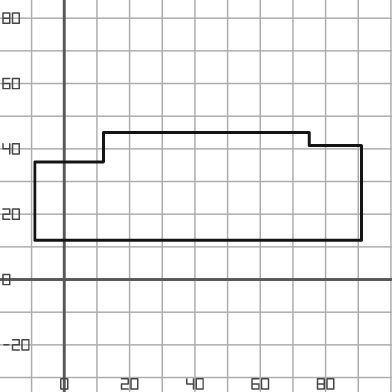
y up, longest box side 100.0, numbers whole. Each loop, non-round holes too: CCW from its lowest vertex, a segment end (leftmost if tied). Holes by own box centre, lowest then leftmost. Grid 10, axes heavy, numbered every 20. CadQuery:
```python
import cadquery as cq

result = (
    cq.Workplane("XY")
    .moveTo(-9.0, 12.0)
    .lineTo(91.0, 12.0)
    .lineTo(91.0, 41.0)
    .lineTo(75.0, 41.0)
    .lineTo(75.0, 45.0)
    .lineTo(12.0, 45.0)
    .lineTo(12.0, 36.0)
    .lineTo(-9.0, 36.0)
    .close()
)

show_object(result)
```